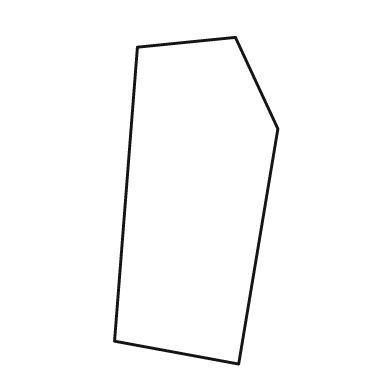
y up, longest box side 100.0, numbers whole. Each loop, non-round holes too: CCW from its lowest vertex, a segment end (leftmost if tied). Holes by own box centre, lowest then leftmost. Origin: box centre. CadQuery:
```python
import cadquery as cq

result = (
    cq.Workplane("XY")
    .moveTo(13.0, -50.0)
    .lineTo(25.0, 22.0)
    .lineTo(12.0, 50.0)
    .lineTo(-18.0, 47.0)
    .lineTo(-25.0, -43.0)
    .close()
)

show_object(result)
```